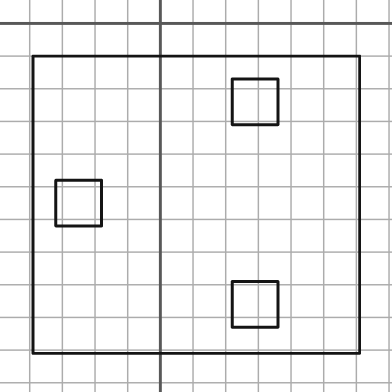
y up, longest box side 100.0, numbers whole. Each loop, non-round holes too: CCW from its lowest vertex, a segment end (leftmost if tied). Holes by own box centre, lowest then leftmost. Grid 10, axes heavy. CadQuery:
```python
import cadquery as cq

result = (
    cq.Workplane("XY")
    .moveTo(-39.0, -101.0)
    .lineTo(61.0, -101.0)
    .lineTo(61.0, -10.0)
    .lineTo(-39.0, -10.0)
    .close()
    .moveTo(22.0, -93.0)
    .lineTo(36.0, -93.0)
    .lineTo(36.0, -79.0)
    .lineTo(22.0, -79.0)
    .close()
    .moveTo(-32.0, -62.0)
    .lineTo(-18.0, -62.0)
    .lineTo(-18.0, -48.0)
    .lineTo(-32.0, -48.0)
    .close()
    .moveTo(22.0, -31.0)
    .lineTo(36.0, -31.0)
    .lineTo(36.0, -17.0)
    .lineTo(22.0, -17.0)
    .close()
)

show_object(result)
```